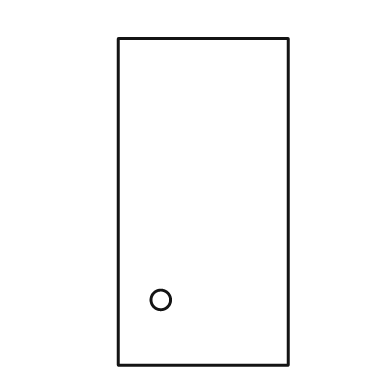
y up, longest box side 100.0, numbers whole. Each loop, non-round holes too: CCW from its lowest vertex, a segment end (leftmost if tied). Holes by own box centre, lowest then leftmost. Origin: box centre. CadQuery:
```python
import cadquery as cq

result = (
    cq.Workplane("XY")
    .moveTo(-26.0, -50.0)
    .lineTo(26.0, -50.0)
    .lineTo(26.0, 50.0)
    .lineTo(-26.0, 50.0)
    .close()
    .moveTo(-13.0, -30.0)
    .circle(3.0)
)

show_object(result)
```